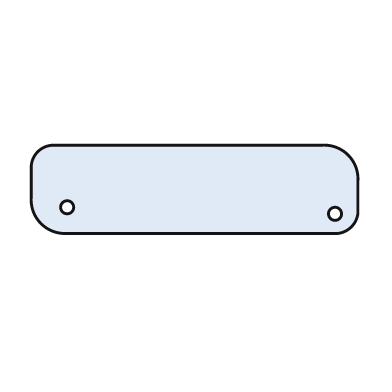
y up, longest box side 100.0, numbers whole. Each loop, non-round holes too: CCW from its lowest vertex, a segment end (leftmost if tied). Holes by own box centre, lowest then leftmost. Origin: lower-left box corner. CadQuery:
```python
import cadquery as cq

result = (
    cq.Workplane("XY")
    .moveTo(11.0, 0.0)
    .lineTo(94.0, 0.0)
    .threePointArc((98.0, 2.0), (100.0, 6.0))
    .lineTo(100.0, 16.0)
    .threePointArc((97.0, 24.0), (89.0, 27.0))
    .lineTo(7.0, 27.0)
    .threePointArc((2.0, 25.0), (0.0, 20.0))
    .lineTo(0.0, 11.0)
    .threePointArc((3.0, 3.0), (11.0, 0.0))
    .close()
    .moveTo(93.0, 6.0)
    .circle(2.0)
    .moveTo(11.0, 8.0)
    .circle(2.0)
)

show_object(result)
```